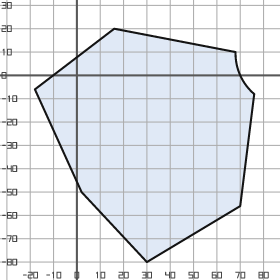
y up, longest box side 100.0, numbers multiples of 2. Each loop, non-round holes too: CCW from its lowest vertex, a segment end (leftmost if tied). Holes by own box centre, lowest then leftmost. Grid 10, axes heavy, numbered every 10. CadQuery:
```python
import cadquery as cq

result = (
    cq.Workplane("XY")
    .moveTo(30.0, -80.0)
    .lineTo(70.0, -56.0)
    .lineTo(76.0, -8.0)
    .threePointArc((70.0, 0.0), (68.0, 10.0))
    .lineTo(16.0, 20.0)
    .lineTo(-18.0, -6.0)
    .lineTo(2.0, -50.0)
    .close()
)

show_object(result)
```